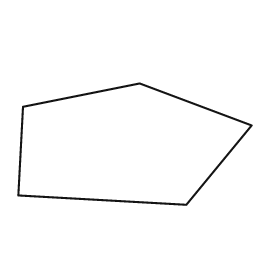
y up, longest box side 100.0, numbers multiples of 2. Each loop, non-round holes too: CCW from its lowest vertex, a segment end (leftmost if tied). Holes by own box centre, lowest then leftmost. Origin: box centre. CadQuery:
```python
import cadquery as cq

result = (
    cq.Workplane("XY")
    .moveTo(22.0, -26.0)
    .lineTo(50.0, 8.0)
    .lineTo(2.0, 26.0)
    .lineTo(-48.0, 16.0)
    .lineTo(-50.0, -22.0)
    .close()
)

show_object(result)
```